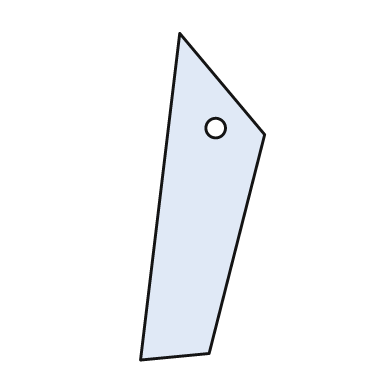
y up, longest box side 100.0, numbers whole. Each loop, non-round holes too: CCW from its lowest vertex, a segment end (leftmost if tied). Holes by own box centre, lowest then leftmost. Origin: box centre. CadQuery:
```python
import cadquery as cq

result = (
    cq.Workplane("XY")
    .moveTo(-19.0, -50.0)
    .lineTo(2.0, -48.0)
    .lineTo(19.0, 19.0)
    .lineTo(-7.0, 50.0)
    .close()
    .moveTo(4.0, 21.0)
    .circle(3.0)
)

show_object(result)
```